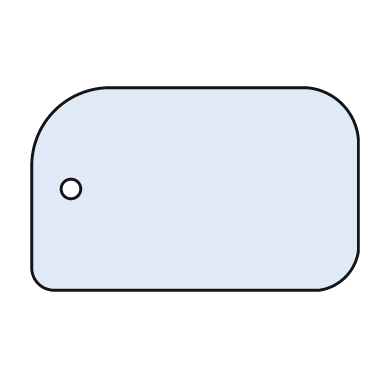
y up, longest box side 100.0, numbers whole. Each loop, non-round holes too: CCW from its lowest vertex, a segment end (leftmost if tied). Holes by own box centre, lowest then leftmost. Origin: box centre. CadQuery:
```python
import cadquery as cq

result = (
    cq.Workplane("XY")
    .moveTo(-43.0, -31.0)
    .lineTo(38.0, -31.0)
    .threePointArc((46.0, -27.0), (50.0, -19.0))
    .lineTo(50.0, 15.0)
    .threePointArc((45.0, 26.0), (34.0, 31.0))
    .lineTo(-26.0, 31.0)
    .threePointArc((-43.0, 24.0), (-50.0, 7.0))
    .lineTo(-50.0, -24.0)
    .threePointArc((-48.0, -29.0), (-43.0, -31.0))
    .close()
    .moveTo(-38.0, 0.0)
    .circle(3.0)
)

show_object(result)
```